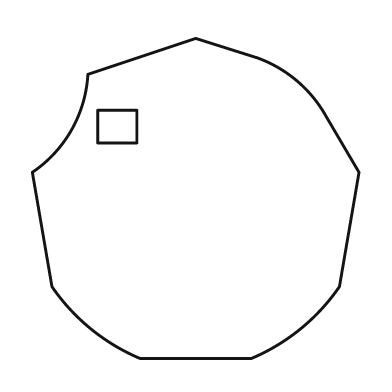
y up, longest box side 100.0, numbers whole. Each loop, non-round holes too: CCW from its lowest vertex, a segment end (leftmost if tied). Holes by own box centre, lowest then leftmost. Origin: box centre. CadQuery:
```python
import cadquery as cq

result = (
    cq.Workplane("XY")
    .moveTo(-17.0, -49.0)
    .lineTo(17.0, -49.0)
    .threePointArc((32.0, -40.0), (44.0, -27.0))
    .lineTo(50.0, 8.0)
    .lineTo(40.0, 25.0)
    .threePointArc((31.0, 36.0), (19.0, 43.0))
    .lineTo(0.0, 49.0)
    .lineTo(-33.0, 38.0)
    .threePointArc((-38.0, 21.0), (-50.0, 8.0))
    .lineTo(-44.0, -27.0)
    .threePointArc((-32.0, -40.0), (-17.0, -49.0))
    .close()
    .moveTo(-30.0, 17.0)
    .lineTo(-18.0, 17.0)
    .lineTo(-18.0, 27.0)
    .lineTo(-30.0, 27.0)
    .close()
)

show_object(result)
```